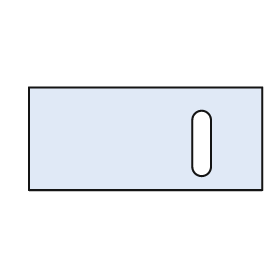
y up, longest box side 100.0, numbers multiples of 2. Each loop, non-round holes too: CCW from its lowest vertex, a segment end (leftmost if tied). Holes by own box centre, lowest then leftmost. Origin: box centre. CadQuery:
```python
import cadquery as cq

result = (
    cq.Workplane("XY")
    .moveTo(-50.0, -22.0)
    .lineTo(50.0, -22.0)
    .lineTo(50.0, 22.0)
    .lineTo(-50.0, 22.0)
    .close()
    .moveTo(20.0, -12.0)
    .threePointArc((24.0, -16.0), (28.0, -12.0))
    .lineTo(28.0, 8.0)
    .threePointArc((24.0, 12.0), (20.0, 8.0))
    .close()
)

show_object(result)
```